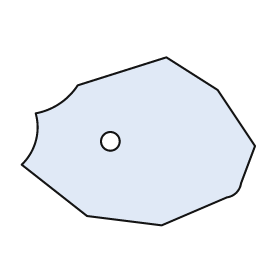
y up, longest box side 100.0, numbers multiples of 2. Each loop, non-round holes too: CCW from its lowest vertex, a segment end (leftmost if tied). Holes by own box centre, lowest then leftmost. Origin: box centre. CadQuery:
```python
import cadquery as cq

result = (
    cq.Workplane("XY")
    .moveTo(10.0, -36.0)
    .lineTo(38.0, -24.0)
    .threePointArc((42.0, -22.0), (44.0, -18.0))
    .lineTo(50.0, -2.0)
    .lineTo(34.0, 22.0)
    .lineTo(12.0, 36.0)
    .lineTo(-26.0, 24.0)
    .threePointArc((-34.0, 16.0), (-44.0, 12.0))
    .threePointArc((-44.0, 0.0), (-50.0, -10.0))
    .lineTo(-22.0, -32.0)
    .close()
    .moveTo(-12.0, 0.0)
    .circle(4.0)
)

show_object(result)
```